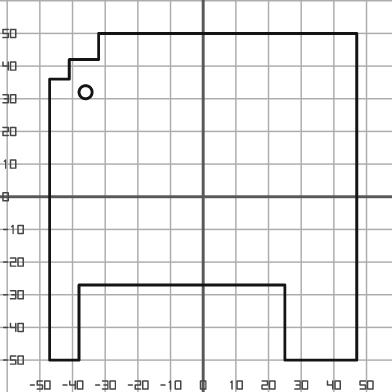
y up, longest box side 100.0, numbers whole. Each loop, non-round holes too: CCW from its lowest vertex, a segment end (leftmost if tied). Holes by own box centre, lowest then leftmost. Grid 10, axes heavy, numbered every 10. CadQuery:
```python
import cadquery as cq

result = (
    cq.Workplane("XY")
    .moveTo(-47.0, -50.0)
    .lineTo(-38.0, -50.0)
    .lineTo(-38.0, -27.0)
    .lineTo(25.0, -27.0)
    .lineTo(25.0, -50.0)
    .lineTo(47.0, -50.0)
    .lineTo(47.0, 50.0)
    .lineTo(-32.0, 50.0)
    .lineTo(-32.0, 42.0)
    .lineTo(-41.0, 42.0)
    .lineTo(-41.0, 36.0)
    .lineTo(-47.0, 36.0)
    .close()
    .moveTo(-36.0, 32.0)
    .circle(2.0)
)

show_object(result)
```